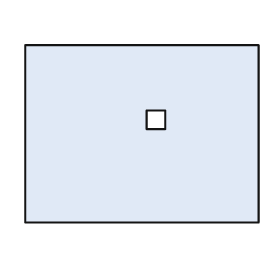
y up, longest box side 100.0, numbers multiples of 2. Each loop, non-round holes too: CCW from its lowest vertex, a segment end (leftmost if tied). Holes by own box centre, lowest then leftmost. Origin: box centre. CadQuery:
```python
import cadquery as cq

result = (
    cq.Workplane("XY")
    .moveTo(-50.0, -38.0)
    .lineTo(50.0, -38.0)
    .lineTo(50.0, 38.0)
    .lineTo(-50.0, 38.0)
    .close()
    .moveTo(2.0, 2.0)
    .lineTo(10.0, 2.0)
    .lineTo(10.0, 10.0)
    .lineTo(2.0, 10.0)
    .close()
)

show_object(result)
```